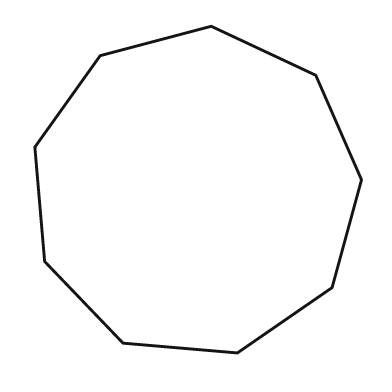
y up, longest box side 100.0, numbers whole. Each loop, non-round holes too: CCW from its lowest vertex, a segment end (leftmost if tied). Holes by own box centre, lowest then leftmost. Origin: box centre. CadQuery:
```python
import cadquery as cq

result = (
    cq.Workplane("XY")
    .moveTo(12.0, -50.0)
    .lineTo(41.0, -30.0)
    .lineTo(50.0, 3.0)
    .lineTo(36.0, 35.0)
    .lineTo(4.0, 50.0)
    .lineTo(-30.0, 41.0)
    .lineTo(-50.0, 13.0)
    .lineTo(-47.0, -22.0)
    .lineTo(-23.0, -47.0)
    .close()
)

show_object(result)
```